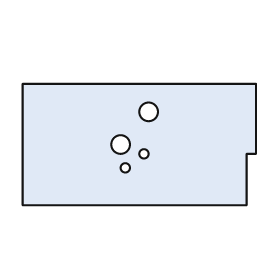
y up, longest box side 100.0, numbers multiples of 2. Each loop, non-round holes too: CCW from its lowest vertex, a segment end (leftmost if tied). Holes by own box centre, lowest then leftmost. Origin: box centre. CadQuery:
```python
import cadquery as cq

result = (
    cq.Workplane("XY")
    .moveTo(-50.0, -26.0)
    .lineTo(46.0, -26.0)
    .lineTo(46.0, -4.0)
    .lineTo(50.0, -4.0)
    .lineTo(50.0, 26.0)
    .lineTo(-50.0, 26.0)
    .close()
    .moveTo(-6.0, -10.0)
    .circle(2.0)
    .moveTo(2.0, -4.0)
    .circle(2.0)
    .moveTo(-8.0, 0.0)
    .circle(4.0)
    .moveTo(4.0, 14.0)
    .circle(4.0)
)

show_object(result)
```